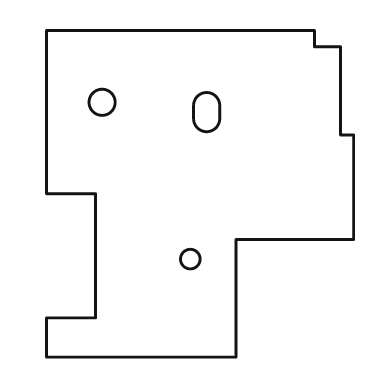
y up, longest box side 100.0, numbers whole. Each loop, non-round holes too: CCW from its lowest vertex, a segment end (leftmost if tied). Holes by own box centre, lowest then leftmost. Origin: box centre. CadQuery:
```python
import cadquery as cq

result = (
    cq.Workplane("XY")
    .moveTo(-47.0, -50.0)
    .lineTo(11.0, -50.0)
    .lineTo(11.0, -14.0)
    .lineTo(47.0, -14.0)
    .lineTo(47.0, 18.0)
    .lineTo(43.0, 18.0)
    .lineTo(43.0, 45.0)
    .lineTo(35.0, 45.0)
    .lineTo(35.0, 50.0)
    .lineTo(-47.0, 50.0)
    .lineTo(-47.0, 0.0)
    .lineTo(-32.0, 0.0)
    .lineTo(-32.0, -38.0)
    .lineTo(-47.0, -38.0)
    .close()
    .moveTo(-3.0, -20.0)
    .circle(3.0)
    .moveTo(-2.0, 23.0)
    .threePointArc((2.0, 19.0), (6.0, 23.0))
    .lineTo(6.0, 27.0)
    .threePointArc((2.0, 31.0), (-2.0, 27.0))
    .close()
    .moveTo(-30.0, 28.0)
    .circle(4.0)
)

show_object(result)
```